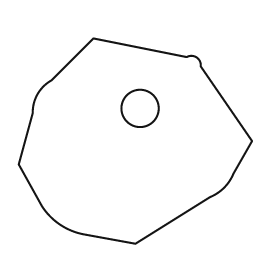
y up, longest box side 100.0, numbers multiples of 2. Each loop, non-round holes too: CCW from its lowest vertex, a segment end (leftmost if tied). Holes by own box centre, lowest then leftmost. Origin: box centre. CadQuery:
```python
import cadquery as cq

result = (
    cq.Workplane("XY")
    .moveTo(0.0, -44.0)
    .lineTo(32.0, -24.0)
    .threePointArc((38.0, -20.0), (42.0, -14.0))
    .lineTo(50.0, 0.0)
    .lineTo(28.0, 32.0)
    .threePointArc((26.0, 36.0), (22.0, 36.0))
    .lineTo(-18.0, 44.0)
    .lineTo(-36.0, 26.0)
    .threePointArc((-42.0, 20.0), (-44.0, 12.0))
    .lineTo(-50.0, -10.0)
    .lineTo(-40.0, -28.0)
    .threePointArc((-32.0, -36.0), (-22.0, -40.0))
    .close()
    .moveTo(2.0, 14.0)
    .circle(8.0)
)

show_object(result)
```